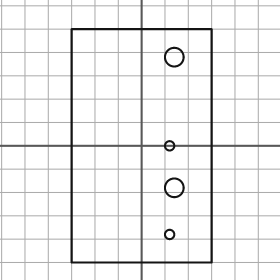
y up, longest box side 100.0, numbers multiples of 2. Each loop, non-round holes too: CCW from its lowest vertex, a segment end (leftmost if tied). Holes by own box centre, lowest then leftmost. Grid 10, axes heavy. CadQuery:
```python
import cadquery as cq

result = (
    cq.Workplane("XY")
    .moveTo(-30.0, -50.0)
    .lineTo(30.0, -50.0)
    .lineTo(30.0, 50.0)
    .lineTo(-30.0, 50.0)
    .close()
    .moveTo(12.0, -38.0)
    .circle(2.0)
    .moveTo(14.0, -18.0)
    .circle(4.0)
    .moveTo(12.0, 0.0)
    .circle(2.0)
    .moveTo(14.0, 38.0)
    .circle(4.0)
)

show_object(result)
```